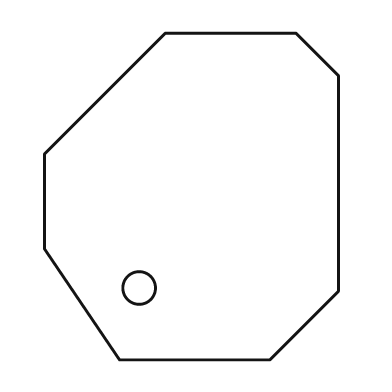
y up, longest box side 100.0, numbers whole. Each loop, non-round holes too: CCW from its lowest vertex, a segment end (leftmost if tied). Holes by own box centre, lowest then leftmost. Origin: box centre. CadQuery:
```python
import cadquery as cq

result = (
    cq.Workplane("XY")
    .moveTo(-22.0, -50.0)
    .lineTo(24.0, -50.0)
    .lineTo(45.0, -29.0)
    .lineTo(45.0, 37.0)
    .lineTo(32.0, 50.0)
    .lineTo(-8.0, 50.0)
    .lineTo(-45.0, 13.0)
    .lineTo(-45.0, -16.0)
    .close()
    .moveTo(-16.0, -28.0)
    .circle(5.0)
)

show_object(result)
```